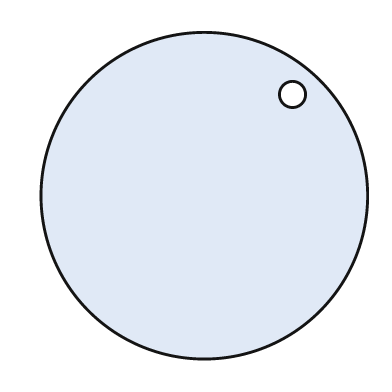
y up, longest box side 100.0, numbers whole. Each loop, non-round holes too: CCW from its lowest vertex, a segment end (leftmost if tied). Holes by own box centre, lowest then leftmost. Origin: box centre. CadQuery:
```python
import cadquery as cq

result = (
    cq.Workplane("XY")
    .moveTo(0.0, 0.0)
    .circle(50.0)
    .moveTo(27.0, 31.0)
    .circle(4.0)
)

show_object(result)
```